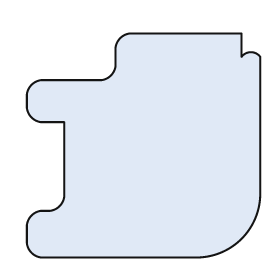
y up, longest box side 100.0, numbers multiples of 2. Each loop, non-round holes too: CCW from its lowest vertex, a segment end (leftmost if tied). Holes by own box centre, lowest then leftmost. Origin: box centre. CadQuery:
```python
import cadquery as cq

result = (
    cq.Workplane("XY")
    .moveTo(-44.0, -48.0)
    .lineTo(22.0, -48.0)
    .threePointArc((42.0, -40.0), (50.0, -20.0))
    .lineTo(50.0, 38.0)
    .threePointArc((46.0, 40.0), (42.0, 38.0))
    .lineTo(42.0, 48.0)
    .lineTo(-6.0, 48.0)
    .threePointArc((-10.0, 46.0), (-12.0, 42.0))
    .lineTo(-12.0, 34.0)
    .threePointArc((-14.0, 30.0), (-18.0, 28.0))
    .lineTo(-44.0, 28.0)
    .threePointArc((-48.0, 26.0), (-50.0, 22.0))
    .lineTo(-50.0, 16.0)
    .threePointArc((-48.0, 12.0), (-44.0, 10.0))
    .lineTo(-34.0, 10.0)
    .lineTo(-34.0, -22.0)
    .threePointArc((-36.0, -26.0), (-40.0, -28.0))
    .lineTo(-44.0, -28.0)
    .threePointArc((-48.0, -30.0), (-50.0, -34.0))
    .lineTo(-50.0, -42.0)
    .threePointArc((-48.0, -46.0), (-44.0, -48.0))
    .close()
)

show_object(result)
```